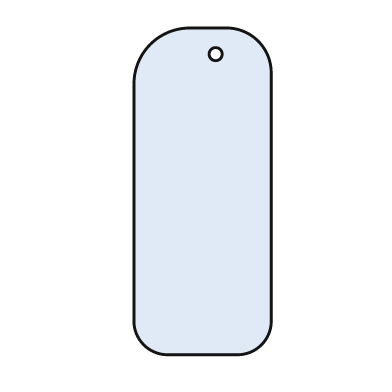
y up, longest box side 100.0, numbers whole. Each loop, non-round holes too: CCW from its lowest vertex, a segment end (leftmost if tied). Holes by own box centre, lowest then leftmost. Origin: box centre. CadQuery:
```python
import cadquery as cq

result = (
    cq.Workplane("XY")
    .moveTo(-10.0, -50.0)
    .lineTo(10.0, -50.0)
    .threePointArc((18.0, -47.0), (21.0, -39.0))
    .lineTo(21.0, 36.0)
    .threePointArc((17.0, 46.0), (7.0, 50.0))
    .lineTo(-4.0, 50.0)
    .threePointArc((-16.0, 45.0), (-21.0, 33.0))
    .lineTo(-21.0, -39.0)
    .threePointArc((-18.0, -47.0), (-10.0, -50.0))
    .close()
    .moveTo(4.0, 42.0)
    .circle(2.0)
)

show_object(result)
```